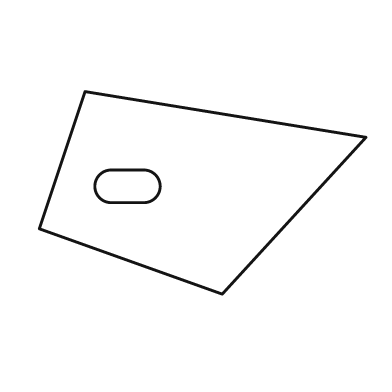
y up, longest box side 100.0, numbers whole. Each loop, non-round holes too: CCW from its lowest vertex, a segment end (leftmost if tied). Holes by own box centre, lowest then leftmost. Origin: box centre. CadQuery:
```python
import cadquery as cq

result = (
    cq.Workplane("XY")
    .moveTo(6.0, -31.0)
    .lineTo(50.0, 17.0)
    .lineTo(-36.0, 31.0)
    .lineTo(-50.0, -11.0)
    .close()
    .moveTo(-28.0, -3.0)
    .lineTo(-18.0, -3.0)
    .threePointArc((-13.0, 2.0), (-18.0, 7.0))
    .lineTo(-28.0, 7.0)
    .threePointArc((-33.0, 2.0), (-28.0, -3.0))
    .close()
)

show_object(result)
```